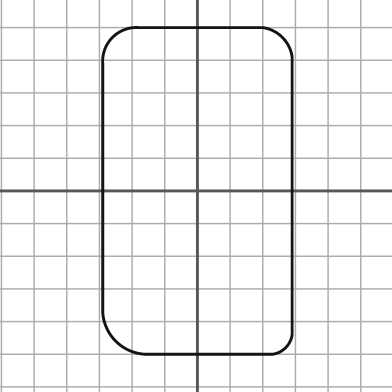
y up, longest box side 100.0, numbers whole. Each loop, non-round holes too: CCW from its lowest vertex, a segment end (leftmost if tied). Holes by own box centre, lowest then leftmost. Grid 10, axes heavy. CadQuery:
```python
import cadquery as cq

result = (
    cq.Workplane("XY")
    .moveTo(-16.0, -50.0)
    .lineTo(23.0, -50.0)
    .threePointArc((27.0, -48.0), (29.0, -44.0))
    .lineTo(29.0, 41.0)
    .threePointArc((26.0, 47.0), (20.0, 50.0))
    .lineTo(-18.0, 50.0)
    .threePointArc((-26.0, 47.0), (-29.0, 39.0))
    .lineTo(-29.0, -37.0)
    .threePointArc((-25.0, -46.0), (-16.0, -50.0))
    .close()
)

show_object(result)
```